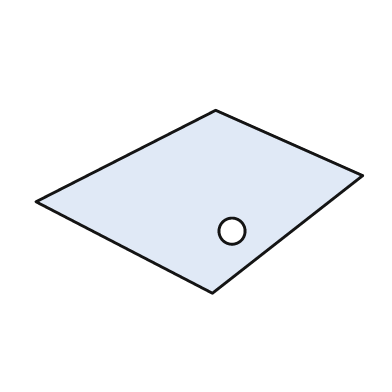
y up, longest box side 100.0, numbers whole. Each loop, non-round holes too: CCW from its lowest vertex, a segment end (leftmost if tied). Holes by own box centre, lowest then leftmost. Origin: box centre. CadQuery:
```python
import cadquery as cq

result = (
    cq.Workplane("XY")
    .moveTo(4.0, -28.0)
    .lineTo(50.0, 8.0)
    .lineTo(5.0, 28.0)
    .lineTo(-50.0, 0.0)
    .close()
    .moveTo(10.0, -9.0)
    .circle(4.0)
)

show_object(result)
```